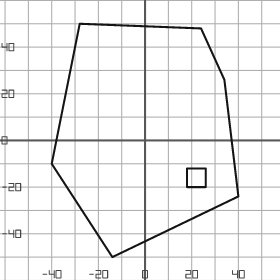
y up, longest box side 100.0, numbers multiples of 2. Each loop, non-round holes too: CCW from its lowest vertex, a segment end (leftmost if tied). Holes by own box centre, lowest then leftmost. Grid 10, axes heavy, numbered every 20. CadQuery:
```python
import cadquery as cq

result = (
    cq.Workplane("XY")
    .moveTo(-14.0, -50.0)
    .lineTo(40.0, -24.0)
    .lineTo(34.0, 26.0)
    .lineTo(24.0, 48.0)
    .lineTo(-28.0, 50.0)
    .lineTo(-40.0, -10.0)
    .close()
    .moveTo(18.0, -20.0)
    .lineTo(26.0, -20.0)
    .lineTo(26.0, -12.0)
    .lineTo(18.0, -12.0)
    .close()
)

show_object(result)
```